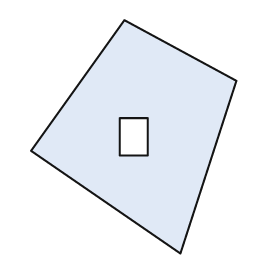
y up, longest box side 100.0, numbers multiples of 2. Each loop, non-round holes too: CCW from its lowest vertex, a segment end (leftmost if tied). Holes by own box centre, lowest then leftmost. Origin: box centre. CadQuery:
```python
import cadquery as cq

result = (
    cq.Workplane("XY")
    .moveTo(20.0, -50.0)
    .lineTo(44.0, 24.0)
    .lineTo(-4.0, 50.0)
    .lineTo(-44.0, -6.0)
    .close()
    .moveTo(-6.0, -8.0)
    .lineTo(6.0, -8.0)
    .lineTo(6.0, 8.0)
    .lineTo(-6.0, 8.0)
    .close()
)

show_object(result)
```